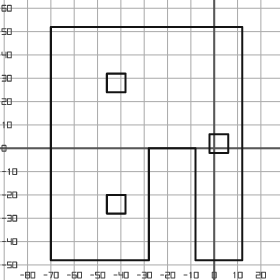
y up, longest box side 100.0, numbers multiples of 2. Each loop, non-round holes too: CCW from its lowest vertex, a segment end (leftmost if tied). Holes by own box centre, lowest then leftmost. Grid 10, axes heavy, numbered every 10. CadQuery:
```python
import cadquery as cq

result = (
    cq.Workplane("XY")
    .moveTo(-70.0, -48.0)
    .lineTo(-28.0, -48.0)
    .lineTo(-28.0, 0.0)
    .lineTo(-8.0, 0.0)
    .lineTo(-8.0, -48.0)
    .lineTo(12.0, -48.0)
    .lineTo(12.0, 52.0)
    .lineTo(-70.0, 52.0)
    .close()
    .moveTo(-46.0, -28.0)
    .lineTo(-38.0, -28.0)
    .lineTo(-38.0, -20.0)
    .lineTo(-46.0, -20.0)
    .close()
    .moveTo(-2.0, -2.0)
    .lineTo(6.0, -2.0)
    .lineTo(6.0, 6.0)
    .lineTo(-2.0, 6.0)
    .close()
    .moveTo(-46.0, 24.0)
    .lineTo(-38.0, 24.0)
    .lineTo(-38.0, 32.0)
    .lineTo(-46.0, 32.0)
    .close()
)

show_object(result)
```